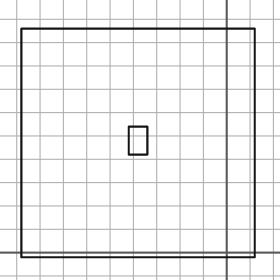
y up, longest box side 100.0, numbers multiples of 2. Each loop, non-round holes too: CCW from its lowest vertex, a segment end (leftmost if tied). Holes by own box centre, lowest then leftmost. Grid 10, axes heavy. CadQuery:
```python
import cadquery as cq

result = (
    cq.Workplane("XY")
    .moveTo(-88.0, -2.0)
    .lineTo(12.0, -2.0)
    .lineTo(12.0, 96.0)
    .lineTo(-88.0, 96.0)
    .close()
    .moveTo(-42.0, 42.0)
    .lineTo(-34.0, 42.0)
    .lineTo(-34.0, 54.0)
    .lineTo(-42.0, 54.0)
    .close()
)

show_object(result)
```